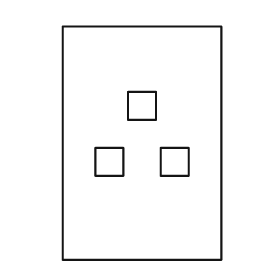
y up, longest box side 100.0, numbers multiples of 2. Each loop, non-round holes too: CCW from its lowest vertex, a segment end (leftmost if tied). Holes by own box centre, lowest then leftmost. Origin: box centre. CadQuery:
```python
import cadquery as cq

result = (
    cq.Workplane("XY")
    .moveTo(-34.0, -50.0)
    .lineTo(34.0, -50.0)
    .lineTo(34.0, 50.0)
    .lineTo(-34.0, 50.0)
    .close()
    .moveTo(-20.0, -14.0)
    .lineTo(-8.0, -14.0)
    .lineTo(-8.0, -2.0)
    .lineTo(-20.0, -2.0)
    .close()
    .moveTo(8.0, -14.0)
    .lineTo(20.0, -14.0)
    .lineTo(20.0, -2.0)
    .lineTo(8.0, -2.0)
    .close()
    .moveTo(-6.0, 10.0)
    .lineTo(6.0, 10.0)
    .lineTo(6.0, 22.0)
    .lineTo(-6.0, 22.0)
    .close()
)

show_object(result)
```